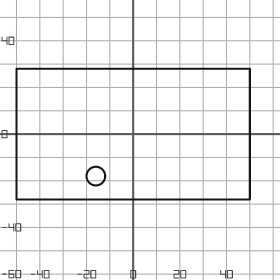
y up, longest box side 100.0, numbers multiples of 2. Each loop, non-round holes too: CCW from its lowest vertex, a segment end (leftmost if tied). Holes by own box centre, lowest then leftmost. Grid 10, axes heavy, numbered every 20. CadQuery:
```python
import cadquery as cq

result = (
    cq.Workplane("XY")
    .moveTo(-50.0, -28.0)
    .lineTo(50.0, -28.0)
    .lineTo(50.0, 28.0)
    .lineTo(-50.0, 28.0)
    .close()
    .moveTo(-16.0, -18.0)
    .circle(4.0)
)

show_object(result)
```